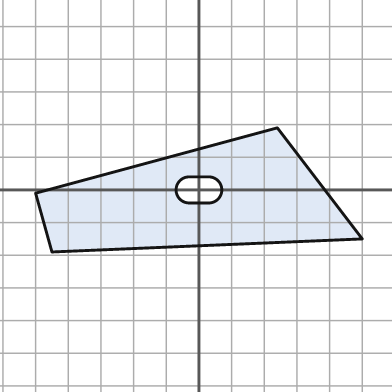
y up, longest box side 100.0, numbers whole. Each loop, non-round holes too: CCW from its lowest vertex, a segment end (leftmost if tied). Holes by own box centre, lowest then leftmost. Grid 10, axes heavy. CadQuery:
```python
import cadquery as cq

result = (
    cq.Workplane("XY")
    .moveTo(-45.0, -19.0)
    .lineTo(50.0, -15.0)
    .lineTo(24.0, 19.0)
    .lineTo(-50.0, -1.0)
    .close()
    .moveTo(-3.0, -4.0)
    .lineTo(3.0, -4.0)
    .threePointArc((7.0, 0.0), (3.0, 4.0))
    .lineTo(-3.0, 4.0)
    .threePointArc((-7.0, 0.0), (-3.0, -4.0))
    .close()
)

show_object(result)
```